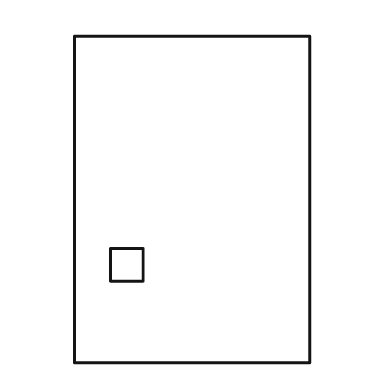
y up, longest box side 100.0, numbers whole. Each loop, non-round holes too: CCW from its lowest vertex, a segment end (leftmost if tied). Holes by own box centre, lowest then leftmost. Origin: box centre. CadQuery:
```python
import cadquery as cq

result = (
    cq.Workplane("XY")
    .moveTo(-36.0, -50.0)
    .lineTo(36.0, -50.0)
    .lineTo(36.0, 50.0)
    .lineTo(-36.0, 50.0)
    .close()
    .moveTo(-25.0, -25.0)
    .lineTo(-15.0, -25.0)
    .lineTo(-15.0, -15.0)
    .lineTo(-25.0, -15.0)
    .close()
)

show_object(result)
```